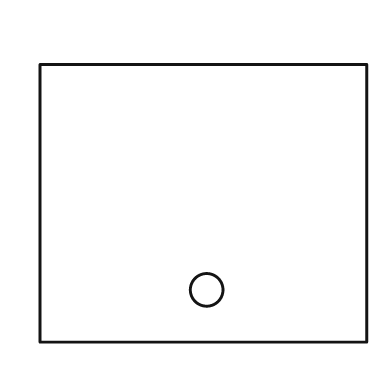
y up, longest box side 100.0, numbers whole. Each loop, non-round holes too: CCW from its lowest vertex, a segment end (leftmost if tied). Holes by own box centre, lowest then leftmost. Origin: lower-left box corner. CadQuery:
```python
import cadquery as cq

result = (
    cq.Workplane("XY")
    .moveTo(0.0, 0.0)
    .lineTo(100.0, 0.0)
    .lineTo(100.0, 85.0)
    .lineTo(0.0, 85.0)
    .close()
    .moveTo(51.0, 16.0)
    .circle(5.0)
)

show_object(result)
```